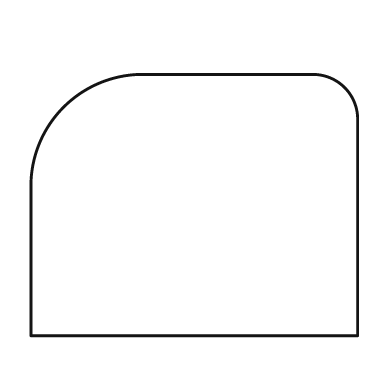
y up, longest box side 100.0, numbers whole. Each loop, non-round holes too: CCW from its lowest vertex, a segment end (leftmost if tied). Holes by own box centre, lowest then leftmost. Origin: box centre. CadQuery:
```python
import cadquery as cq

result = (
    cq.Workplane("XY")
    .moveTo(-50.0, -40.0)
    .lineTo(50.0, -40.0)
    .lineTo(50.0, 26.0)
    .threePointArc((46.0, 36.0), (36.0, 40.0))
    .lineTo(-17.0, 40.0)
    .threePointArc((-40.0, 30.0), (-50.0, 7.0))
    .close()
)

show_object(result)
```